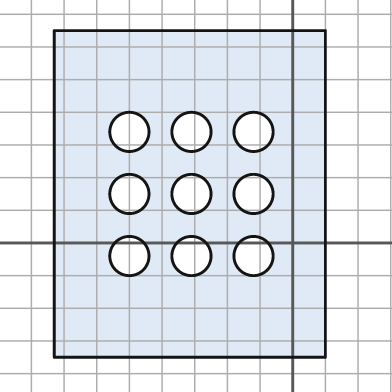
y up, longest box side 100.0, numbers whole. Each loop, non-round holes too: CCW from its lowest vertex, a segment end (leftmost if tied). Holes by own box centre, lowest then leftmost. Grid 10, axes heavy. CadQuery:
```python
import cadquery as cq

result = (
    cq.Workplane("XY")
    .moveTo(-73.0, -35.0)
    .lineTo(10.0, -35.0)
    .lineTo(10.0, 65.0)
    .lineTo(-73.0, 65.0)
    .close()
    .moveTo(-50.0, -4.0)
    .circle(6.0)
    .moveTo(-31.0, -4.0)
    .circle(6.0)
    .moveTo(-12.0, -4.0)
    .circle(6.0)
    .moveTo(-50.0, 15.0)
    .circle(6.0)
    .moveTo(-31.0, 15.0)
    .circle(6.0)
    .moveTo(-12.0, 15.0)
    .circle(6.0)
    .moveTo(-50.0, 34.0)
    .circle(6.0)
    .moveTo(-31.0, 34.0)
    .circle(6.0)
    .moveTo(-12.0, 34.0)
    .circle(6.0)
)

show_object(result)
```